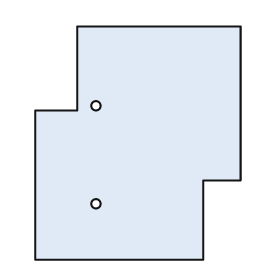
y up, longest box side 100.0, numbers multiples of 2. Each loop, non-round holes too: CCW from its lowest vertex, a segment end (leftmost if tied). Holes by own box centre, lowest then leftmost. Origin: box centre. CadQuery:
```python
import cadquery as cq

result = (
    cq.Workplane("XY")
    .moveTo(-44.0, -50.0)
    .lineTo(28.0, -50.0)
    .lineTo(28.0, -16.0)
    .lineTo(44.0, -16.0)
    .lineTo(44.0, 50.0)
    .lineTo(-26.0, 50.0)
    .lineTo(-26.0, 14.0)
    .lineTo(-44.0, 14.0)
    .close()
    .moveTo(-18.0, -26.0)
    .circle(2.0)
    .moveTo(-18.0, 16.0)
    .circle(2.0)
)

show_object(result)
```